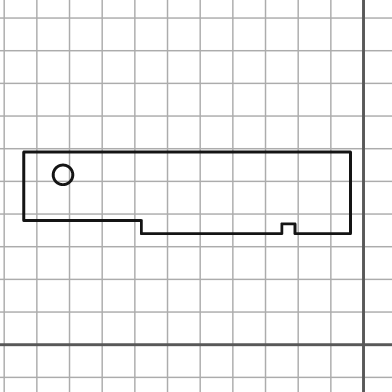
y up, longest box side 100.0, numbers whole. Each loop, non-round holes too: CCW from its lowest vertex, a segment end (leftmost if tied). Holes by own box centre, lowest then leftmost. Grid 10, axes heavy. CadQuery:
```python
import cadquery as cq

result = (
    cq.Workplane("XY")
    .moveTo(-68.0, 34.0)
    .lineTo(-25.0, 34.0)
    .lineTo(-25.0, 37.0)
    .lineTo(-21.0, 37.0)
    .lineTo(-21.0, 34.0)
    .lineTo(-4.0, 34.0)
    .lineTo(-4.0, 59.0)
    .lineTo(-104.0, 59.0)
    .lineTo(-104.0, 38.0)
    .lineTo(-68.0, 38.0)
    .close()
    .moveTo(-92.0, 52.0)
    .circle(3.0)
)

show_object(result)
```